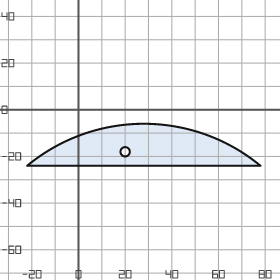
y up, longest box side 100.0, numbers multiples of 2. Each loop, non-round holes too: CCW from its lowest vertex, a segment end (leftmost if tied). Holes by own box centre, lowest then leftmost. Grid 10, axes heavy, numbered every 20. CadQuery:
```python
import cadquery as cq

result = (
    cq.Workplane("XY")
    .moveTo(-22.0, -24.0)
    .lineTo(78.0, -24.0)
    .threePointArc((28.0, -6.0), (-22.0, -24.0))
    .close()
    .moveTo(20.0, -18.0)
    .circle(2.0)
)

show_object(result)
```